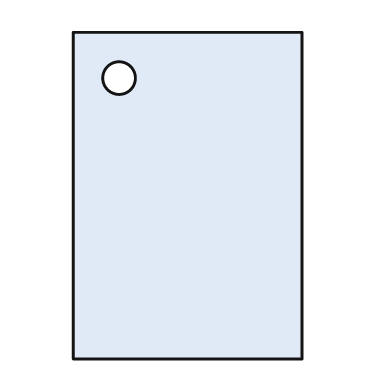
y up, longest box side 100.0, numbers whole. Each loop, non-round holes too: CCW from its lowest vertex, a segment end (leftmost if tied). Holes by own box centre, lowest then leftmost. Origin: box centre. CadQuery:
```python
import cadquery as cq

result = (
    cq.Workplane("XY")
    .moveTo(-35.0, -50.0)
    .lineTo(35.0, -50.0)
    .lineTo(35.0, 50.0)
    .lineTo(-35.0, 50.0)
    .close()
    .moveTo(-21.0, 36.0)
    .circle(5.0)
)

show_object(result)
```